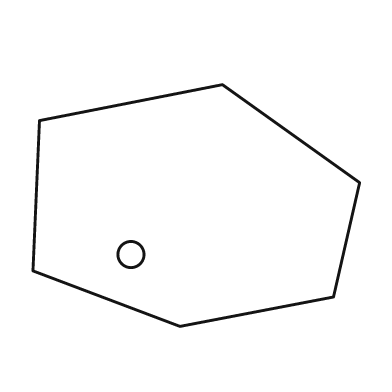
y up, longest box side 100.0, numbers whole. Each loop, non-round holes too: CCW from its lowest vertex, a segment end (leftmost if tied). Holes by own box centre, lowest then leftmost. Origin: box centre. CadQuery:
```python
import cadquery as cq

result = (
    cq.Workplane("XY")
    .moveTo(-5.0, -37.0)
    .lineTo(42.0, -28.0)
    .lineTo(50.0, 7.0)
    .lineTo(8.0, 37.0)
    .lineTo(-48.0, 26.0)
    .lineTo(-50.0, -20.0)
    .close()
    .moveTo(-20.0, -15.0)
    .circle(4.0)
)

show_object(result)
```